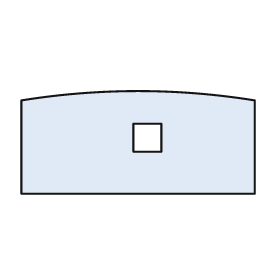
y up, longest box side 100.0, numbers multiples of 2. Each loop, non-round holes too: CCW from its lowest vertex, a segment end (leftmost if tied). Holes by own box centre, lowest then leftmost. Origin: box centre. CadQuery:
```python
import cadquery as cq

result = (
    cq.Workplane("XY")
    .moveTo(-50.0, -22.0)
    .lineTo(50.0, -22.0)
    .lineTo(50.0, 18.0)
    .threePointArc((0.0, 22.0), (-50.0, 18.0))
    .close()
    .moveTo(-2.0, -4.0)
    .lineTo(10.0, -4.0)
    .lineTo(10.0, 8.0)
    .lineTo(-2.0, 8.0)
    .close()
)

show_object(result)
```